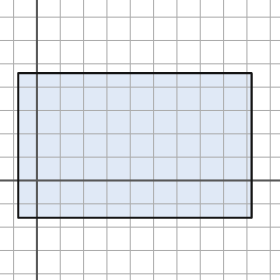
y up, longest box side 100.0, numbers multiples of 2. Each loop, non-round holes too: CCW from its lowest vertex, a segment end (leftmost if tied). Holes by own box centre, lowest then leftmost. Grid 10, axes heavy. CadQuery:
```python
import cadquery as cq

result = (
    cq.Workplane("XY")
    .moveTo(-8.0, -16.0)
    .lineTo(92.0, -16.0)
    .lineTo(92.0, 46.0)
    .lineTo(-8.0, 46.0)
    .close()
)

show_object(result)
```